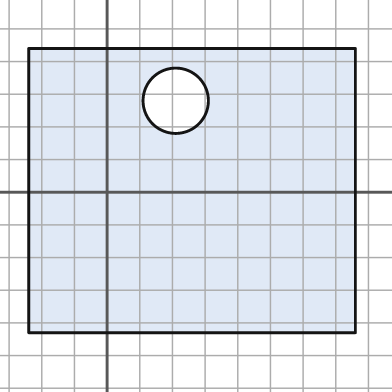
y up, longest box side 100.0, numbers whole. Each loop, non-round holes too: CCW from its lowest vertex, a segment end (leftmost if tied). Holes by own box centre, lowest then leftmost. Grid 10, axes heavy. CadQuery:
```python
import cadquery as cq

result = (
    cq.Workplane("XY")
    .moveTo(-24.0, -43.0)
    .lineTo(76.0, -43.0)
    .lineTo(76.0, 44.0)
    .lineTo(-24.0, 44.0)
    .close()
    .moveTo(21.0, 28.0)
    .circle(10.0)
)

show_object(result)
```